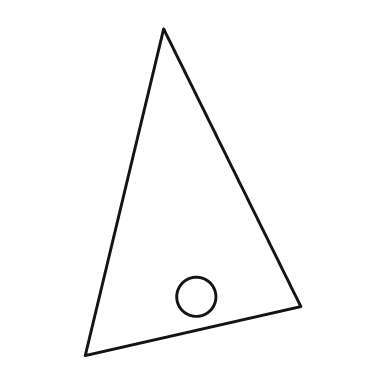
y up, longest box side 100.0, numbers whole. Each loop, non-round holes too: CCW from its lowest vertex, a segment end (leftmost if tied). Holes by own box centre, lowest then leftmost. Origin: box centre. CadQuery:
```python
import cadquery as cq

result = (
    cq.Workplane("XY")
    .moveTo(-33.0, -50.0)
    .lineTo(33.0, -35.0)
    .lineTo(-9.0, 50.0)
    .close()
    .moveTo(1.0, -32.0)
    .circle(6.0)
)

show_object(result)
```